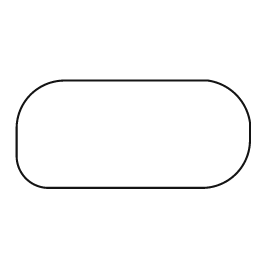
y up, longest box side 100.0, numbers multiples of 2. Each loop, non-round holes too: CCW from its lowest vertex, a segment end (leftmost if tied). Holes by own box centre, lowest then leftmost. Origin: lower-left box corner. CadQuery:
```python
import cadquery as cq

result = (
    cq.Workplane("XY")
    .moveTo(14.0, 0.0)
    .lineTo(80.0, 0.0)
    .threePointArc((94.0, 6.0), (100.0, 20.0))
    .lineTo(100.0, 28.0)
    .threePointArc((94.0, 40.0), (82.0, 46.0))
    .lineTo(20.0, 46.0)
    .threePointArc((6.0, 40.0), (0.0, 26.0))
    .lineTo(0.0, 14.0)
    .threePointArc((4.0, 4.0), (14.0, 0.0))
    .close()
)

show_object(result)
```